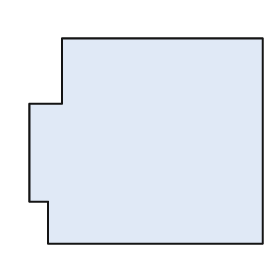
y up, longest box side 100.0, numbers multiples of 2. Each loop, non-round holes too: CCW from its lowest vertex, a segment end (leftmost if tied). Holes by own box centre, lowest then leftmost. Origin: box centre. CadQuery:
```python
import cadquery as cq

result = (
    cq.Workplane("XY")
    .moveTo(-42.0, -44.0)
    .lineTo(50.0, -44.0)
    .lineTo(50.0, 44.0)
    .lineTo(-36.0, 44.0)
    .lineTo(-36.0, 16.0)
    .lineTo(-50.0, 16.0)
    .lineTo(-50.0, -26.0)
    .lineTo(-42.0, -26.0)
    .close()
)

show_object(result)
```